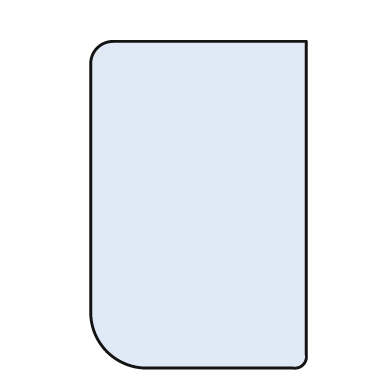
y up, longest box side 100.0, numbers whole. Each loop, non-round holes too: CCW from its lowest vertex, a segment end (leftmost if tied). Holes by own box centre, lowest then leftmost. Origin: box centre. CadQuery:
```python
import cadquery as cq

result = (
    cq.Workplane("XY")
    .moveTo(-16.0, -50.0)
    .lineTo(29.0, -50.0)
    .threePointArc((32.0, -49.0), (33.0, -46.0))
    .lineTo(33.0, 50.0)
    .lineTo(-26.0, 50.0)
    .threePointArc((-31.0, 48.0), (-33.0, 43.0))
    .lineTo(-33.0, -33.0)
    .threePointArc((-28.0, -45.0), (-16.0, -50.0))
    .close()
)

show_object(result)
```